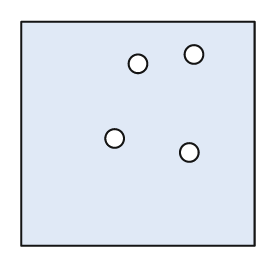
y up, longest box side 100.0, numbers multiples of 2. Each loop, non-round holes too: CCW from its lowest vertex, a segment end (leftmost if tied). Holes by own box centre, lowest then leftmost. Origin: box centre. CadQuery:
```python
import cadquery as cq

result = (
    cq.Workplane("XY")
    .moveTo(-50.0, -48.0)
    .lineTo(50.0, -48.0)
    .lineTo(50.0, 48.0)
    .lineTo(-50.0, 48.0)
    .close()
    .moveTo(22.0, -8.0)
    .circle(4.0)
    .moveTo(-10.0, -2.0)
    .circle(4.0)
    .moveTo(0.0, 30.0)
    .circle(4.0)
    .moveTo(24.0, 34.0)
    .circle(4.0)
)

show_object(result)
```